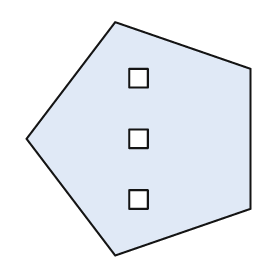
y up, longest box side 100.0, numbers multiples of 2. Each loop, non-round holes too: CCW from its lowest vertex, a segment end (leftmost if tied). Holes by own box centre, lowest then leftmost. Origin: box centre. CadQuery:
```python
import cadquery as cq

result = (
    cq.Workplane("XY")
    .moveTo(-10.0, -50.0)
    .lineTo(48.0, -30.0)
    .lineTo(48.0, 30.0)
    .lineTo(-10.0, 50.0)
    .lineTo(-48.0, 0.0)
    .close()
    .moveTo(-4.0, -30.0)
    .lineTo(4.0, -30.0)
    .lineTo(4.0, -22.0)
    .lineTo(-4.0, -22.0)
    .close()
    .moveTo(-4.0, -4.0)
    .lineTo(4.0, -4.0)
    .lineTo(4.0, 4.0)
    .lineTo(-4.0, 4.0)
    .close()
    .moveTo(-4.0, 22.0)
    .lineTo(4.0, 22.0)
    .lineTo(4.0, 30.0)
    .lineTo(-4.0, 30.0)
    .close()
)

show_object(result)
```